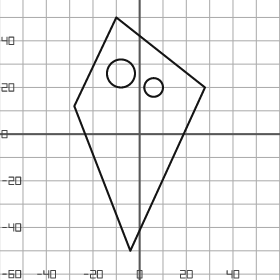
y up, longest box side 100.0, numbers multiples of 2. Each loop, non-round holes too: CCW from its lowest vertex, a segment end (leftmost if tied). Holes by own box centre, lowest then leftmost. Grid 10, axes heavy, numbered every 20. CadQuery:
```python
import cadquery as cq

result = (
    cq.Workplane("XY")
    .moveTo(-4.0, -50.0)
    .lineTo(28.0, 20.0)
    .lineTo(-10.0, 50.0)
    .lineTo(-28.0, 12.0)
    .close()
    .moveTo(6.0, 20.0)
    .circle(4.0)
    .moveTo(-8.0, 26.0)
    .circle(6.0)
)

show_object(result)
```